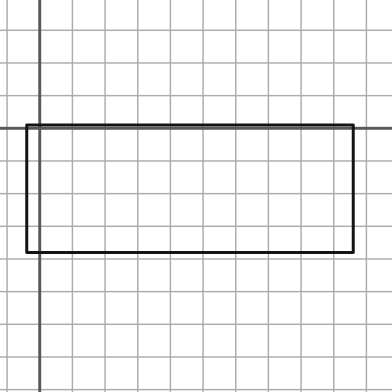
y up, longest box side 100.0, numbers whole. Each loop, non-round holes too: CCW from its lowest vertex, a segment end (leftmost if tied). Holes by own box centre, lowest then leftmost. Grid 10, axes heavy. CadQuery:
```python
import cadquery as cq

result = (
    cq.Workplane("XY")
    .moveTo(-4.0, -38.0)
    .lineTo(96.0, -38.0)
    .lineTo(96.0, 1.0)
    .lineTo(-4.0, 1.0)
    .close()
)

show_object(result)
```